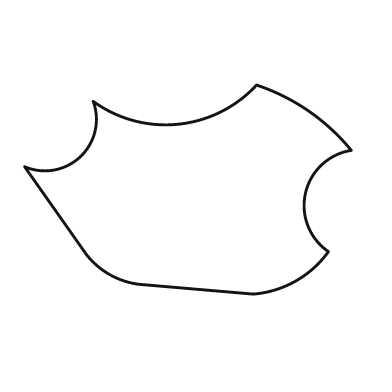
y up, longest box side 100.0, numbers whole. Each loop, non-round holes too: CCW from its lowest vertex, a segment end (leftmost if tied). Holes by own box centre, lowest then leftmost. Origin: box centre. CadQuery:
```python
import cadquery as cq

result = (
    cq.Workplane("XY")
    .moveTo(20.0, -32.0)
    .threePointArc((33.0, -28.0), (43.0, -19.0))
    .threePointArc((36.0, -1.0), (50.0, 12.0))
    .threePointArc((37.0, 24.0), (21.0, 32.0))
    .threePointArc((-3.0, 20.0), (-29.0, 27.0))
    .threePointArc((-33.0, 10.0), (-50.0, 7.0))
    .lineTo(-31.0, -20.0)
    .threePointArc((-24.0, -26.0), (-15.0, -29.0))
    .close()
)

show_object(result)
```